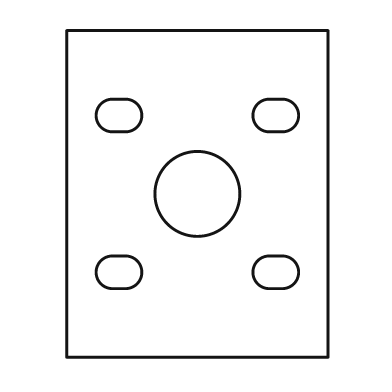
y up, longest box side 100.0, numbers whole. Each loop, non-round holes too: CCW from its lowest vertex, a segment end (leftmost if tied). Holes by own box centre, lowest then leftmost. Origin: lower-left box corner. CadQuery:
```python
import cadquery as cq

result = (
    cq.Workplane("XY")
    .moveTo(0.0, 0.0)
    .lineTo(80.0, 0.0)
    .lineTo(80.0, 100.0)
    .lineTo(0.0, 100.0)
    .close()
    .moveTo(14.0, 21.0)
    .lineTo(18.0, 21.0)
    .threePointArc((23.0, 26.0), (18.0, 31.0))
    .lineTo(14.0, 31.0)
    .threePointArc((9.0, 26.0), (14.0, 21.0))
    .close()
    .moveTo(62.0, 21.0)
    .lineTo(66.0, 21.0)
    .threePointArc((71.0, 26.0), (66.0, 31.0))
    .lineTo(62.0, 31.0)
    .threePointArc((57.0, 26.0), (62.0, 21.0))
    .close()
    .moveTo(40.0, 50.0)
    .circle(13.0)
    .moveTo(14.0, 69.0)
    .lineTo(18.0, 69.0)
    .threePointArc((23.0, 74.0), (18.0, 79.0))
    .lineTo(14.0, 79.0)
    .threePointArc((9.0, 74.0), (14.0, 69.0))
    .close()
    .moveTo(62.0, 69.0)
    .lineTo(66.0, 69.0)
    .threePointArc((71.0, 74.0), (66.0, 79.0))
    .lineTo(62.0, 79.0)
    .threePointArc((57.0, 74.0), (62.0, 69.0))
    .close()
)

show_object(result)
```